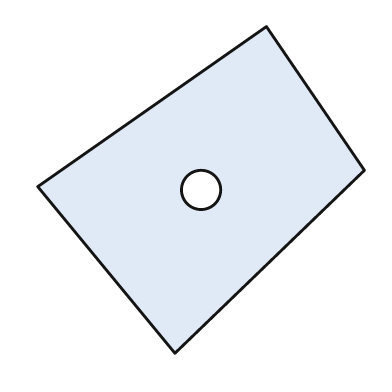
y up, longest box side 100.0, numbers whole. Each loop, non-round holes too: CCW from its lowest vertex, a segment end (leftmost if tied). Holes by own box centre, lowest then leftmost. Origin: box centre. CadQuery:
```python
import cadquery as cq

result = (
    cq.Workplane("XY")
    .moveTo(-8.0, -50.0)
    .lineTo(50.0, 6.0)
    .lineTo(20.0, 50.0)
    .lineTo(-50.0, 1.0)
    .close()
    .moveTo(0.0, 0.0)
    .circle(6.0)
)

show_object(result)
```